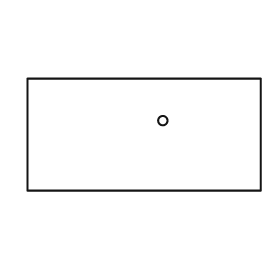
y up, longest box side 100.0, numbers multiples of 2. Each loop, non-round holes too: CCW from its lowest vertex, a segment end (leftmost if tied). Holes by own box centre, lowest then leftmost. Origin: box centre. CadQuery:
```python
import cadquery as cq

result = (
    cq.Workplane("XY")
    .moveTo(-50.0, -24.0)
    .lineTo(50.0, -24.0)
    .lineTo(50.0, 24.0)
    .lineTo(-50.0, 24.0)
    .close()
    .moveTo(8.0, 6.0)
    .circle(2.0)
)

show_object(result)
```